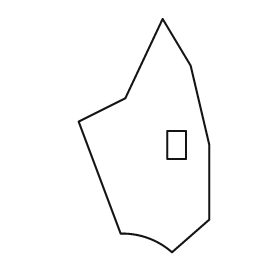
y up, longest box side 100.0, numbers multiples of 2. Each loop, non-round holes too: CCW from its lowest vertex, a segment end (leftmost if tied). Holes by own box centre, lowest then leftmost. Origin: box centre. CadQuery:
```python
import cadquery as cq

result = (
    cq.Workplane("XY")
    .moveTo(12.0, -50.0)
    .lineTo(28.0, -36.0)
    .lineTo(28.0, -4.0)
    .lineTo(20.0, 30.0)
    .lineTo(8.0, 50.0)
    .lineTo(-8.0, 16.0)
    .lineTo(-28.0, 6.0)
    .lineTo(-10.0, -42.0)
    .threePointArc((2.0, -44.0), (12.0, -50.0))
    .close()
    .moveTo(10.0, -10.0)
    .lineTo(18.0, -10.0)
    .lineTo(18.0, 2.0)
    .lineTo(10.0, 2.0)
    .close()
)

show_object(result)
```